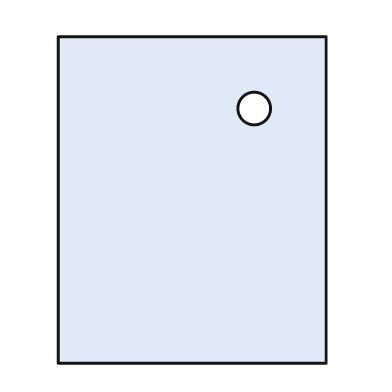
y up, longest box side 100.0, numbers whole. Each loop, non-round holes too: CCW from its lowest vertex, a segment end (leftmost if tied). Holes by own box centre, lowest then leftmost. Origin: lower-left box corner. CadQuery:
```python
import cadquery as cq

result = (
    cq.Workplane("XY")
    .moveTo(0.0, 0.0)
    .lineTo(82.0, 0.0)
    .lineTo(82.0, 100.0)
    .lineTo(0.0, 100.0)
    .close()
    .moveTo(60.0, 78.0)
    .circle(5.0)
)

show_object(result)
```